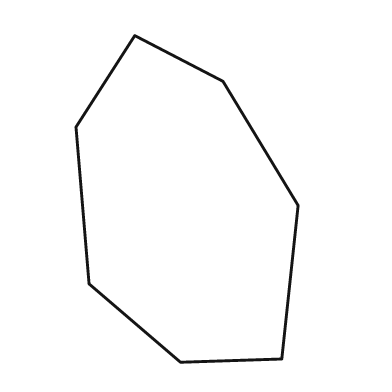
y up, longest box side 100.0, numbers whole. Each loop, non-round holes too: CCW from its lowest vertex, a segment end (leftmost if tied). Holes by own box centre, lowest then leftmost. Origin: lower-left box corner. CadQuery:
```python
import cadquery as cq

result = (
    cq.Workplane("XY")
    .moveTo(32.0, 0.0)
    .lineTo(63.0, 1.0)
    .lineTo(68.0, 48.0)
    .lineTo(45.0, 86.0)
    .lineTo(18.0, 100.0)
    .lineTo(0.0, 72.0)
    .lineTo(4.0, 24.0)
    .close()
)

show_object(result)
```